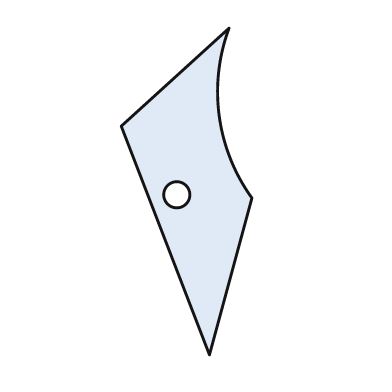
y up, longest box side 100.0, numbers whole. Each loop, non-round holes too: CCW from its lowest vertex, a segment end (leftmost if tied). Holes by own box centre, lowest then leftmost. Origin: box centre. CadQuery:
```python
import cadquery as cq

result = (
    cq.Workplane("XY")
    .moveTo(7.0, -50.0)
    .lineTo(20.0, -2.0)
    .threePointArc((10.0, 23.0), (13.0, 50.0))
    .lineTo(-20.0, 20.0)
    .close()
    .moveTo(-3.0, -1.0)
    .circle(4.0)
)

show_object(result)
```